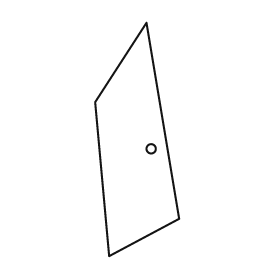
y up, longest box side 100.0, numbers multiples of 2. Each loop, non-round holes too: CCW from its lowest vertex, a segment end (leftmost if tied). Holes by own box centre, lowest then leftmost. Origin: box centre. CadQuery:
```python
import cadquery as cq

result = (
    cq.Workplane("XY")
    .moveTo(-12.0, -50.0)
    .lineTo(18.0, -34.0)
    .lineTo(4.0, 50.0)
    .lineTo(-18.0, 16.0)
    .close()
    .moveTo(6.0, -4.0)
    .circle(2.0)
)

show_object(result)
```